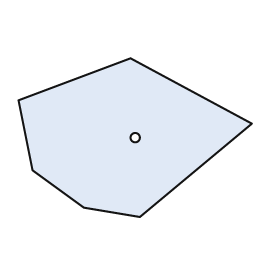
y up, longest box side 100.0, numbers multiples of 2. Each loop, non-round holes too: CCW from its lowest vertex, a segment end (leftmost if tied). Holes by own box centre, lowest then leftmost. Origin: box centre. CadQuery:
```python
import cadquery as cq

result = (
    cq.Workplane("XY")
    .moveTo(2.0, -34.0)
    .lineTo(50.0, 6.0)
    .lineTo(-2.0, 34.0)
    .lineTo(-50.0, 16.0)
    .lineTo(-44.0, -14.0)
    .lineTo(-22.0, -30.0)
    .close()
    .moveTo(0.0, 0.0)
    .circle(2.0)
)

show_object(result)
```